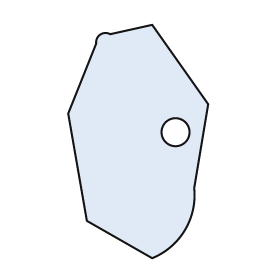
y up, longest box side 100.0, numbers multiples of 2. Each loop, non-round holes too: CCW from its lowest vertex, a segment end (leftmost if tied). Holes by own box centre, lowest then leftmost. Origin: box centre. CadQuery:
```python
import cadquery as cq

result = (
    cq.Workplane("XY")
    .moveTo(6.0, -50.0)
    .threePointArc((20.0, -38.0), (24.0, -20.0))
    .lineTo(30.0, 16.0)
    .lineTo(6.0, 50.0)
    .lineTo(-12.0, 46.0)
    .threePointArc((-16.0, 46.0), (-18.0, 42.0))
    .lineTo(-30.0, 12.0)
    .lineTo(-22.0, -34.0)
    .close()
    .moveTo(16.0, 4.0)
    .circle(6.0)
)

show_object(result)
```